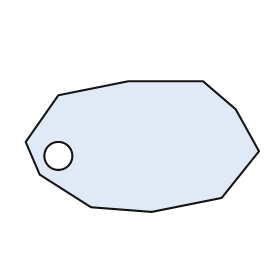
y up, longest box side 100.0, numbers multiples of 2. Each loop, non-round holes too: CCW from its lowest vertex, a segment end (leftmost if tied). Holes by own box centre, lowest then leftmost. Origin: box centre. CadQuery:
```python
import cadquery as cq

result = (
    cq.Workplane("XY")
    .moveTo(4.0, -28.0)
    .lineTo(34.0, -22.0)
    .lineTo(50.0, -2.0)
    .lineTo(40.0, 16.0)
    .lineTo(26.0, 28.0)
    .lineTo(-6.0, 28.0)
    .lineTo(-36.0, 22.0)
    .lineTo(-50.0, 2.0)
    .lineTo(-44.0, -12.0)
    .lineTo(-22.0, -26.0)
    .close()
    .moveTo(-36.0, -4.0)
    .circle(6.0)
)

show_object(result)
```